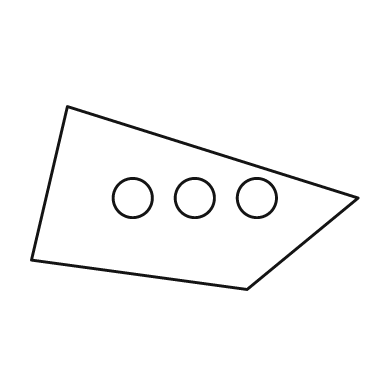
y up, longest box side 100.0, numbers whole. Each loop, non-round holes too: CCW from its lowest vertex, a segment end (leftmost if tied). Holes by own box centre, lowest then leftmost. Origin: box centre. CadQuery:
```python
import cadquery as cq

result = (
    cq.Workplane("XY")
    .moveTo(16.0, -28.0)
    .lineTo(50.0, 0.0)
    .lineTo(-39.0, 28.0)
    .lineTo(-50.0, -19.0)
    .close()
    .moveTo(-19.0, 0.0)
    .circle(6.0)
    .moveTo(0.0, 0.0)
    .circle(6.0)
    .moveTo(19.0, 0.0)
    .circle(6.0)
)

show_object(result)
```